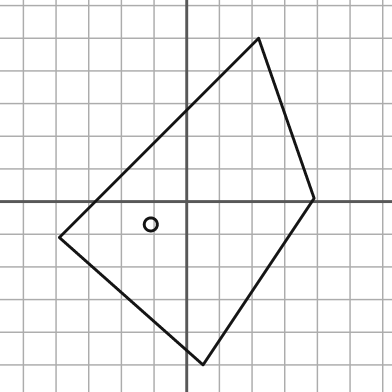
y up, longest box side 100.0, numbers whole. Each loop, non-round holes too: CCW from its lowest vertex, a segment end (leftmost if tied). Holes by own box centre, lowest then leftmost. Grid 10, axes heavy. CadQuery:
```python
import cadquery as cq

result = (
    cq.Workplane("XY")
    .moveTo(5.0, -50.0)
    .lineTo(39.0, 1.0)
    .lineTo(22.0, 50.0)
    .lineTo(-39.0, -11.0)
    .close()
    .moveTo(-11.0, -7.0)
    .circle(2.0)
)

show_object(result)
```